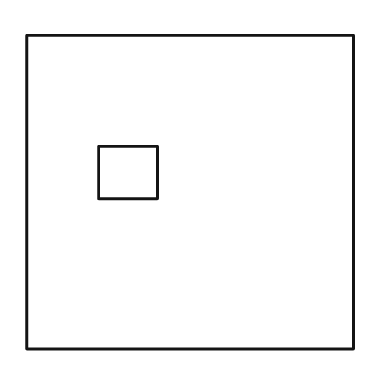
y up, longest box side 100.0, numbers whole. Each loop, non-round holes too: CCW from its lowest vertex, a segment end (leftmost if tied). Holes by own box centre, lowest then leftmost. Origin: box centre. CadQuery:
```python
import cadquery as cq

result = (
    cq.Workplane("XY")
    .moveTo(-50.0, -48.0)
    .lineTo(50.0, -48.0)
    .lineTo(50.0, 48.0)
    .lineTo(-50.0, 48.0)
    .close()
    .moveTo(-28.0, -2.0)
    .lineTo(-10.0, -2.0)
    .lineTo(-10.0, 14.0)
    .lineTo(-28.0, 14.0)
    .close()
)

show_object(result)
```